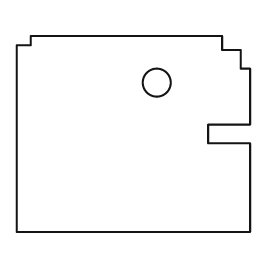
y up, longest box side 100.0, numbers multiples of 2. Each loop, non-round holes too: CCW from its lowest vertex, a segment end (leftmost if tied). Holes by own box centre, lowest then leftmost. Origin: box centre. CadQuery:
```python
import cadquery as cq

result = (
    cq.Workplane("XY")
    .moveTo(-50.0, -42.0)
    .lineTo(50.0, -42.0)
    .lineTo(50.0, -4.0)
    .lineTo(32.0, -4.0)
    .lineTo(32.0, 4.0)
    .lineTo(50.0, 4.0)
    .lineTo(50.0, 28.0)
    .lineTo(46.0, 28.0)
    .lineTo(46.0, 36.0)
    .lineTo(38.0, 36.0)
    .lineTo(38.0, 42.0)
    .lineTo(-44.0, 42.0)
    .lineTo(-44.0, 38.0)
    .lineTo(-50.0, 38.0)
    .close()
    .moveTo(10.0, 22.0)
    .circle(6.0)
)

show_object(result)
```